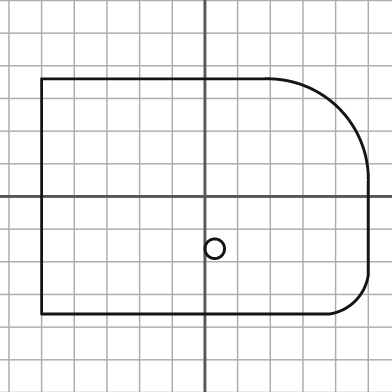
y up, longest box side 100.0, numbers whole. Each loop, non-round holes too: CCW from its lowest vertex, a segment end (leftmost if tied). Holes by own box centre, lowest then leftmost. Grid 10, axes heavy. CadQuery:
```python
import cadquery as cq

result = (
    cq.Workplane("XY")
    .moveTo(-50.0, -36.0)
    .lineTo(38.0, -36.0)
    .threePointArc((46.0, -32.0), (50.0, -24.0))
    .lineTo(50.0, 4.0)
    .threePointArc((41.0, 27.0), (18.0, 36.0))
    .lineTo(-50.0, 36.0)
    .close()
    .moveTo(3.0, -16.0)
    .circle(3.0)
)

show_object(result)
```